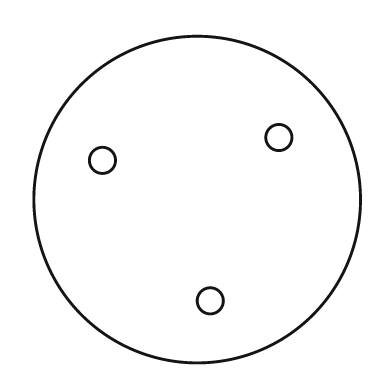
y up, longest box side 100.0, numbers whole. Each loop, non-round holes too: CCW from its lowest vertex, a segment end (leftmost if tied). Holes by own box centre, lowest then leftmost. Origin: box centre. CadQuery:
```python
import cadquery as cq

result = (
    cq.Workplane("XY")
    .moveTo(0.0, 0.0)
    .circle(50.0)
    .moveTo(4.0, -31.0)
    .circle(4.0)
    .moveTo(-29.0, 12.0)
    .circle(4.0)
    .moveTo(25.0, 19.0)
    .circle(4.0)
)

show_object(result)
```